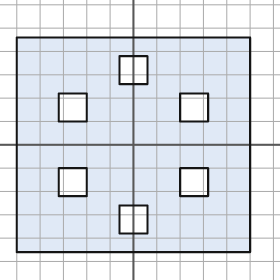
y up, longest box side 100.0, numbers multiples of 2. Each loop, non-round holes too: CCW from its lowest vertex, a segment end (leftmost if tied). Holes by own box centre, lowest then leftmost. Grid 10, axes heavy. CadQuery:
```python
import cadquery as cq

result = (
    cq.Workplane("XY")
    .moveTo(-50.0, -46.0)
    .lineTo(50.0, -46.0)
    .lineTo(50.0, 46.0)
    .lineTo(-50.0, 46.0)
    .close()
    .moveTo(-6.0, -38.0)
    .lineTo(6.0, -38.0)
    .lineTo(6.0, -26.0)
    .lineTo(-6.0, -26.0)
    .close()
    .moveTo(-32.0, -22.0)
    .lineTo(-20.0, -22.0)
    .lineTo(-20.0, -10.0)
    .lineTo(-32.0, -10.0)
    .close()
    .moveTo(20.0, -22.0)
    .lineTo(32.0, -22.0)
    .lineTo(32.0, -10.0)
    .lineTo(20.0, -10.0)
    .close()
    .moveTo(-32.0, 10.0)
    .lineTo(-20.0, 10.0)
    .lineTo(-20.0, 22.0)
    .lineTo(-32.0, 22.0)
    .close()
    .moveTo(20.0, 10.0)
    .lineTo(32.0, 10.0)
    .lineTo(32.0, 22.0)
    .lineTo(20.0, 22.0)
    .close()
    .moveTo(-6.0, 26.0)
    .lineTo(6.0, 26.0)
    .lineTo(6.0, 38.0)
    .lineTo(-6.0, 38.0)
    .close()
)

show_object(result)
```